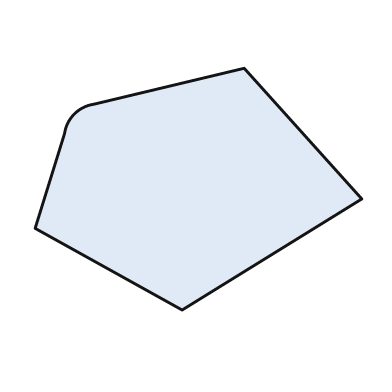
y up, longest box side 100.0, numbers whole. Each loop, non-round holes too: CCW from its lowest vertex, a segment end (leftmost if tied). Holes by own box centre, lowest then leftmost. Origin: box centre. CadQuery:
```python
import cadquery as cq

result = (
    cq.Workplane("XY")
    .moveTo(-5.0, -37.0)
    .lineTo(50.0, -3.0)
    .lineTo(14.0, 37.0)
    .lineTo(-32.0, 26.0)
    .threePointArc((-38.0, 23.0), (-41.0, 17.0))
    .lineTo(-50.0, -12.0)
    .close()
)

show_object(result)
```